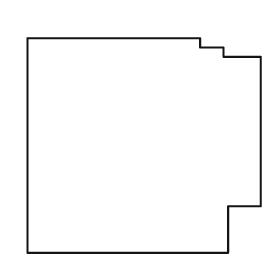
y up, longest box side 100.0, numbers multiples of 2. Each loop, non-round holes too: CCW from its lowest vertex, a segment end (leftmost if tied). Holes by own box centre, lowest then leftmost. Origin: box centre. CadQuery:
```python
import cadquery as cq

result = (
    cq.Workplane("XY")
    .moveTo(-50.0, -46.0)
    .lineTo(36.0, -46.0)
    .lineTo(36.0, -26.0)
    .lineTo(50.0, -26.0)
    .lineTo(50.0, 38.0)
    .lineTo(34.0, 38.0)
    .lineTo(34.0, 42.0)
    .lineTo(24.0, 42.0)
    .lineTo(24.0, 46.0)
    .lineTo(-50.0, 46.0)
    .close()
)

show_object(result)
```